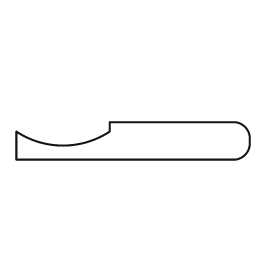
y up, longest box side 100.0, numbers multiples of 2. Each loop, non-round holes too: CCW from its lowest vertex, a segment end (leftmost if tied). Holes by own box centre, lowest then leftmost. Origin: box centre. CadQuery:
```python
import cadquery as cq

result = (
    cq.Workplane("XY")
    .moveTo(-50.0, -8.0)
    .lineTo(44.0, -8.0)
    .threePointArc((48.0, -6.0), (50.0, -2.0))
    .lineTo(50.0, 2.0)
    .threePointArc((48.0, 6.0), (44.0, 8.0))
    .lineTo(-10.0, 8.0)
    .lineTo(-10.0, 4.0)
    .threePointArc((-30.0, -2.0), (-50.0, 4.0))
    .close()
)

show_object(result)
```